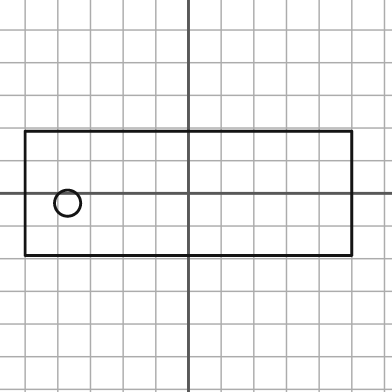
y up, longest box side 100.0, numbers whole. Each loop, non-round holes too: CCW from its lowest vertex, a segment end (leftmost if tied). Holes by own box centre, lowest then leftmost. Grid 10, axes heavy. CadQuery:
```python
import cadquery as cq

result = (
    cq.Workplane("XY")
    .moveTo(-50.0, -19.0)
    .lineTo(50.0, -19.0)
    .lineTo(50.0, 19.0)
    .lineTo(-50.0, 19.0)
    .close()
    .moveTo(-37.0, -3.0)
    .circle(4.0)
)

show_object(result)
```